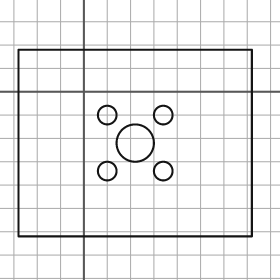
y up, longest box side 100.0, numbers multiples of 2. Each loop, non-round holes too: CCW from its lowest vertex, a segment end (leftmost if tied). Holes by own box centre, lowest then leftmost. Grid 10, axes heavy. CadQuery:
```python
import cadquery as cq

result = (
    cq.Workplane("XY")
    .moveTo(-28.0, -62.0)
    .lineTo(72.0, -62.0)
    .lineTo(72.0, 18.0)
    .lineTo(-28.0, 18.0)
    .close()
    .moveTo(10.0, -34.0)
    .circle(4.0)
    .moveTo(34.0, -34.0)
    .circle(4.0)
    .moveTo(22.0, -22.0)
    .circle(8.0)
    .moveTo(10.0, -10.0)
    .circle(4.0)
    .moveTo(34.0, -10.0)
    .circle(4.0)
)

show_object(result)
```